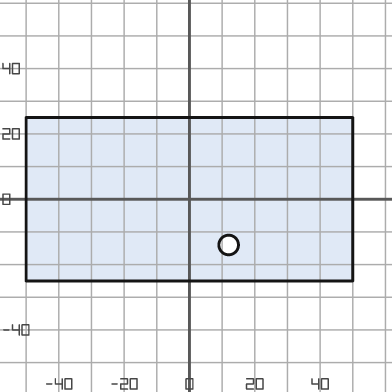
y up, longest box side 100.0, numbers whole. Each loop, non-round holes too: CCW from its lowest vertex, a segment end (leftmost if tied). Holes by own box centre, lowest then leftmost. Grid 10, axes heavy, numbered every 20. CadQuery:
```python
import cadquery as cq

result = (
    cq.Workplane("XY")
    .moveTo(-50.0, -25.0)
    .lineTo(50.0, -25.0)
    .lineTo(50.0, 25.0)
    .lineTo(-50.0, 25.0)
    .close()
    .moveTo(12.0, -14.0)
    .circle(3.0)
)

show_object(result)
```